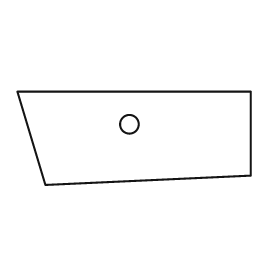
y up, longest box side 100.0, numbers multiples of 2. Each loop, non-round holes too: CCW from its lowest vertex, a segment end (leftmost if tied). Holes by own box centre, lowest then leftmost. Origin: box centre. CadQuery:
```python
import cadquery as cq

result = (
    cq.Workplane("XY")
    .moveTo(-38.0, -20.0)
    .lineTo(50.0, -16.0)
    .lineTo(50.0, 20.0)
    .lineTo(-50.0, 20.0)
    .close()
    .moveTo(-2.0, 6.0)
    .circle(4.0)
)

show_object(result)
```